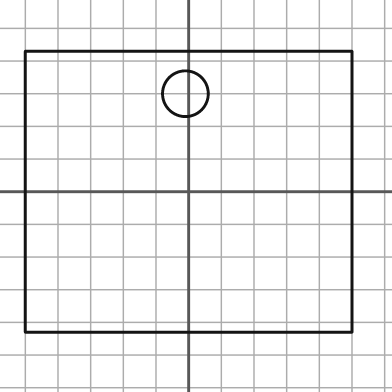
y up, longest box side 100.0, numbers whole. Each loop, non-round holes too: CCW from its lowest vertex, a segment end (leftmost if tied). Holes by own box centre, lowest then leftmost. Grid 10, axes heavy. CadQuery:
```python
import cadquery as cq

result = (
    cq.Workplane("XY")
    .moveTo(-50.0, -43.0)
    .lineTo(50.0, -43.0)
    .lineTo(50.0, 43.0)
    .lineTo(-50.0, 43.0)
    .close()
    .moveTo(-1.0, 30.0)
    .circle(7.0)
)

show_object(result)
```